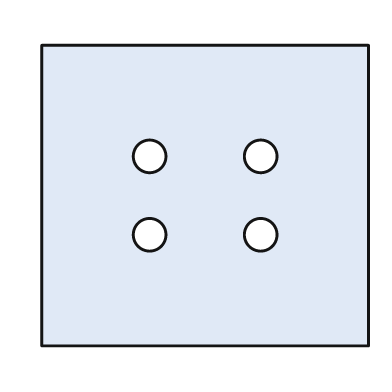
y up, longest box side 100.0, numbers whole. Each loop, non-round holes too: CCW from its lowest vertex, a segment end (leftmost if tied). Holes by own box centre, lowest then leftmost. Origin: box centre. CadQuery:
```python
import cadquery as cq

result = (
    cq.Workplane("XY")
    .moveTo(-50.0, -46.0)
    .lineTo(50.0, -46.0)
    .lineTo(50.0, 46.0)
    .lineTo(-50.0, 46.0)
    .close()
    .moveTo(-17.0, -12.0)
    .circle(5.0)
    .moveTo(17.0, -12.0)
    .circle(5.0)
    .moveTo(-17.0, 12.0)
    .circle(5.0)
    .moveTo(17.0, 12.0)
    .circle(5.0)
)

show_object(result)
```